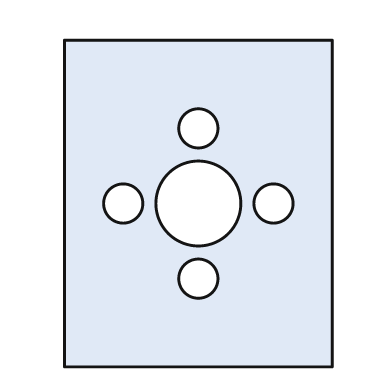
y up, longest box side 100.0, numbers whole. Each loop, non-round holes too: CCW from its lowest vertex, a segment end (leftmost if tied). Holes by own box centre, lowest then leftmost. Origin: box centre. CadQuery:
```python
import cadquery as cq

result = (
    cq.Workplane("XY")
    .moveTo(-41.0, -50.0)
    .lineTo(41.0, -50.0)
    .lineTo(41.0, 50.0)
    .lineTo(-41.0, 50.0)
    .close()
    .moveTo(0.0, -23.0)
    .circle(6.0)
    .moveTo(-23.0, 0.0)
    .circle(6.0)
    .moveTo(0.0, 0.0)
    .circle(13.0)
    .moveTo(23.0, 0.0)
    .circle(6.0)
    .moveTo(0.0, 23.0)
    .circle(6.0)
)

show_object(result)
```